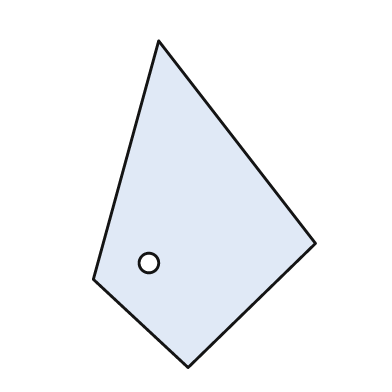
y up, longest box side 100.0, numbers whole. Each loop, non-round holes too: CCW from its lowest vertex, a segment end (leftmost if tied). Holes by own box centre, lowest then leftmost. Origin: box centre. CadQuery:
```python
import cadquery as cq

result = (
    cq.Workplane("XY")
    .moveTo(-5.0, -50.0)
    .lineTo(34.0, -12.0)
    .lineTo(-14.0, 50.0)
    .lineTo(-34.0, -23.0)
    .close()
    .moveTo(-17.0, -18.0)
    .circle(3.0)
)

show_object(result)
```